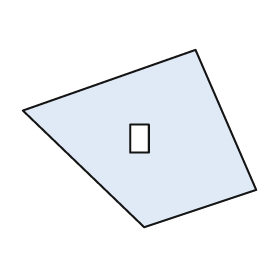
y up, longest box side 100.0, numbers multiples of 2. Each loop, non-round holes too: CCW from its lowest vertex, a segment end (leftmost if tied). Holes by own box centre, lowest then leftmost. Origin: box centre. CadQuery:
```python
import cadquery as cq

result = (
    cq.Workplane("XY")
    .moveTo(2.0, -38.0)
    .lineTo(50.0, -22.0)
    .lineTo(24.0, 38.0)
    .lineTo(-50.0, 12.0)
    .close()
    .moveTo(-4.0, -6.0)
    .lineTo(4.0, -6.0)
    .lineTo(4.0, 6.0)
    .lineTo(-4.0, 6.0)
    .close()
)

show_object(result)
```